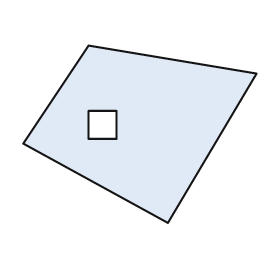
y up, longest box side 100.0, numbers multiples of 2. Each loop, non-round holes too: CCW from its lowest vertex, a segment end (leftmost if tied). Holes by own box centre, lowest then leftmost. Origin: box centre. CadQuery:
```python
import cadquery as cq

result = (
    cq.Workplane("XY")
    .moveTo(12.0, -38.0)
    .lineTo(50.0, 26.0)
    .lineTo(-22.0, 38.0)
    .lineTo(-50.0, -4.0)
    .close()
    .moveTo(-22.0, -2.0)
    .lineTo(-10.0, -2.0)
    .lineTo(-10.0, 10.0)
    .lineTo(-22.0, 10.0)
    .close()
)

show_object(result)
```